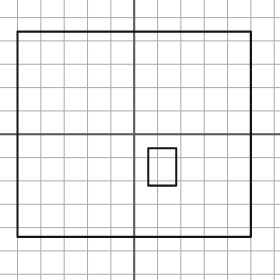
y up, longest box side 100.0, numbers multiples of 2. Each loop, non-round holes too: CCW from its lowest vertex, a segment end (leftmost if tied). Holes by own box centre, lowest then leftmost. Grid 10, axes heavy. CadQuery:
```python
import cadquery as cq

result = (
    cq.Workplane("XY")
    .moveTo(-50.0, -44.0)
    .lineTo(50.0, -44.0)
    .lineTo(50.0, 44.0)
    .lineTo(-50.0, 44.0)
    .close()
    .moveTo(6.0, -22.0)
    .lineTo(18.0, -22.0)
    .lineTo(18.0, -6.0)
    .lineTo(6.0, -6.0)
    .close()
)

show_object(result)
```